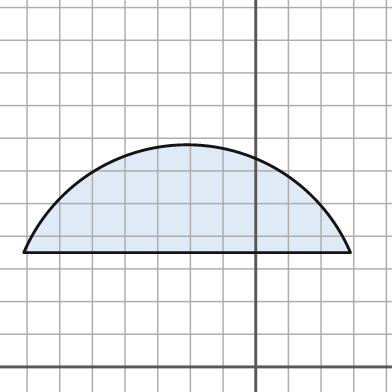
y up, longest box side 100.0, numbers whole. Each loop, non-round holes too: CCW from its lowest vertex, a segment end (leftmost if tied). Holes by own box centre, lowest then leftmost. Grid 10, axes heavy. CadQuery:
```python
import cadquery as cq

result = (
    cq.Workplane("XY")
    .moveTo(-71.0, 35.0)
    .lineTo(29.0, 35.0)
    .threePointArc((-21.0, 68.0), (-71.0, 35.0))
    .close()
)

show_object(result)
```